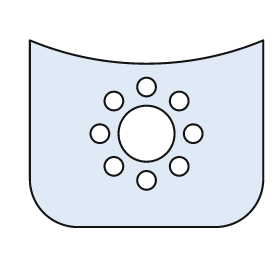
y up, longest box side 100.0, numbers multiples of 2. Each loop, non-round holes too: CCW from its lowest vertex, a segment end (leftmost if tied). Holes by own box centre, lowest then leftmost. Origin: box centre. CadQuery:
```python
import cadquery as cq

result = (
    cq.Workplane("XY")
    .moveTo(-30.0, -40.0)
    .lineTo(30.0, -40.0)
    .threePointArc((44.0, -34.0), (50.0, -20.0))
    .lineTo(50.0, 40.0)
    .threePointArc((0.0, 30.0), (-50.0, 40.0))
    .lineTo(-50.0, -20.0)
    .threePointArc((-44.0, -34.0), (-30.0, -40.0))
    .close()
    .moveTo(0.0, -20.0)
    .circle(4.0)
    .moveTo(-14.0, -14.0)
    .circle(4.0)
    .moveTo(14.0, -14.0)
    .circle(4.0)
    .moveTo(-20.0, 0.0)
    .circle(4.0)
    .moveTo(0.0, 0.0)
    .circle(12.0)
    .moveTo(20.0, 0.0)
    .circle(4.0)
    .moveTo(-14.0, 14.0)
    .circle(4.0)
    .moveTo(14.0, 14.0)
    .circle(4.0)
    .moveTo(0.0, 20.0)
    .circle(4.0)
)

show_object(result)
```